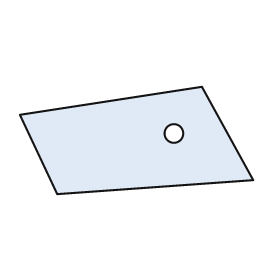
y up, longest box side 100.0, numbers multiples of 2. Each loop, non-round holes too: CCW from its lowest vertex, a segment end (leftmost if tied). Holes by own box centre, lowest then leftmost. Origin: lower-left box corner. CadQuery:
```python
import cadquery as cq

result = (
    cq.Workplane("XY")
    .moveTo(16.0, 0.0)
    .lineTo(100.0, 6.0)
    .lineTo(78.0, 46.0)
    .lineTo(0.0, 34.0)
    .close()
    .moveTo(66.0, 26.0)
    .circle(4.0)
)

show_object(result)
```